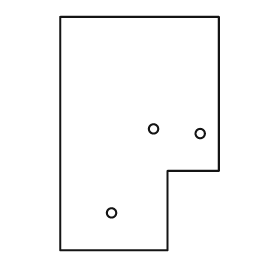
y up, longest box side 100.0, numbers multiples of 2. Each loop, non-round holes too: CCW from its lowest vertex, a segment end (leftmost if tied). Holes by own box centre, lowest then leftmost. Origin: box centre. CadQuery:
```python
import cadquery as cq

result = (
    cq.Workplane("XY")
    .moveTo(-34.0, -50.0)
    .lineTo(12.0, -50.0)
    .lineTo(12.0, -16.0)
    .lineTo(34.0, -16.0)
    .lineTo(34.0, 50.0)
    .lineTo(-34.0, 50.0)
    .close()
    .moveTo(-12.0, -34.0)
    .circle(2.0)
    .moveTo(26.0, 0.0)
    .circle(2.0)
    .moveTo(6.0, 2.0)
    .circle(2.0)
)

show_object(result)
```